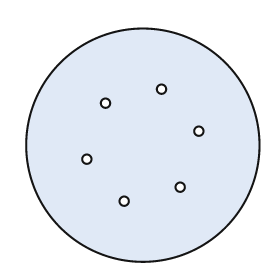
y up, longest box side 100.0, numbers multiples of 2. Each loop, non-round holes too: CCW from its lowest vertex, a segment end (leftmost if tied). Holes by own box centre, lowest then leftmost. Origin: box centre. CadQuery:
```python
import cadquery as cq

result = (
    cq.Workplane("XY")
    .moveTo(0.0, 0.0)
    .circle(50.0)
    .moveTo(-8.0, -24.0)
    .circle(2.0)
    .moveTo(16.0, -18.0)
    .circle(2.0)
    .moveTo(-24.0, -6.0)
    .circle(2.0)
    .moveTo(24.0, 6.0)
    .circle(2.0)
    .moveTo(-16.0, 18.0)
    .circle(2.0)
    .moveTo(8.0, 24.0)
    .circle(2.0)
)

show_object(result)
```